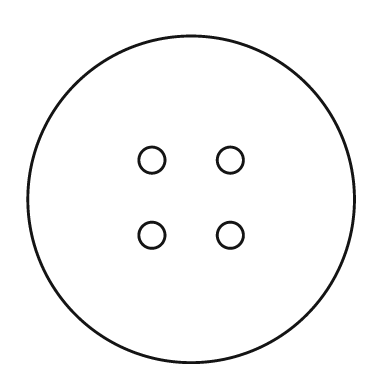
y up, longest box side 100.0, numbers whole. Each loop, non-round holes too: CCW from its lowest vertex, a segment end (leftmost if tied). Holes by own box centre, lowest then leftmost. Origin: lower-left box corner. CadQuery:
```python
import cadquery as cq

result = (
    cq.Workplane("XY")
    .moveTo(50.0, 50.0)
    .circle(50.0)
    .moveTo(38.0, 39.0)
    .circle(4.0)
    .moveTo(62.0, 39.0)
    .circle(4.0)
    .moveTo(38.0, 62.0)
    .circle(4.0)
    .moveTo(62.0, 62.0)
    .circle(4.0)
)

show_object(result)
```